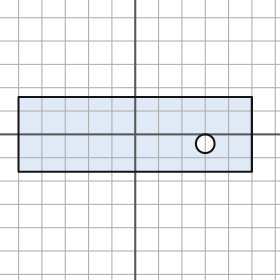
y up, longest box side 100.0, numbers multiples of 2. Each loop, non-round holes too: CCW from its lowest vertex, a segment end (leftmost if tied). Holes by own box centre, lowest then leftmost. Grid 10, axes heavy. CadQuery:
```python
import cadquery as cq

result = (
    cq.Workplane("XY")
    .moveTo(-50.0, -16.0)
    .lineTo(50.0, -16.0)
    .lineTo(50.0, 16.0)
    .lineTo(-50.0, 16.0)
    .close()
    .moveTo(30.0, -4.0)
    .circle(4.0)
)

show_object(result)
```